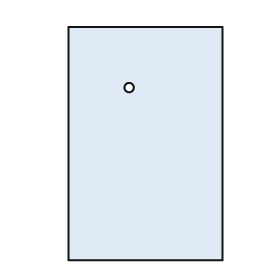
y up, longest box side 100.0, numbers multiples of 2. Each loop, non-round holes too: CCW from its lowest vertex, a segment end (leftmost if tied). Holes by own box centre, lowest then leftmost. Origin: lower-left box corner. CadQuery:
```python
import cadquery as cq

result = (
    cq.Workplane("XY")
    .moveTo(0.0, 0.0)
    .lineTo(66.0, 0.0)
    .lineTo(66.0, 100.0)
    .lineTo(0.0, 100.0)
    .close()
    .moveTo(26.0, 74.0)
    .circle(2.0)
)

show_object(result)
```